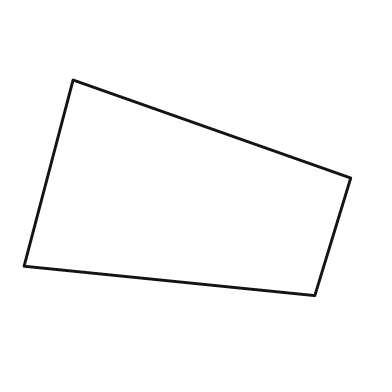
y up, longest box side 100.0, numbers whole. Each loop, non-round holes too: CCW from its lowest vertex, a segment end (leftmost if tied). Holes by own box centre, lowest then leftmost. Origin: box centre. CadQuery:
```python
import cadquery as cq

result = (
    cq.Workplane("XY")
    .moveTo(39.0, -33.0)
    .lineTo(50.0, 3.0)
    .lineTo(-35.0, 33.0)
    .lineTo(-50.0, -24.0)
    .close()
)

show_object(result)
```